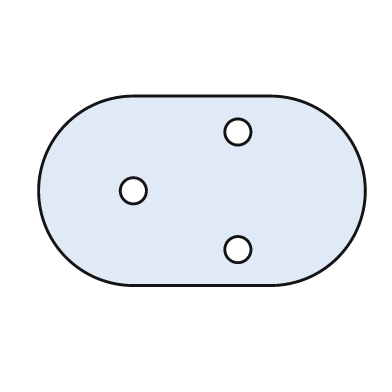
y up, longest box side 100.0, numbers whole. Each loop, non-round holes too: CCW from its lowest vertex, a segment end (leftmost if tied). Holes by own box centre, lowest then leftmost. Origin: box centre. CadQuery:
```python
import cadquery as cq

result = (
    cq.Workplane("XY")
    .moveTo(-21.0, -29.0)
    .lineTo(21.0, -29.0)
    .threePointArc((50.0, 0.0), (21.0, 29.0))
    .lineTo(-21.0, 29.0)
    .threePointArc((-50.0, 0.0), (-21.0, -29.0))
    .close()
    .moveTo(11.0, -18.0)
    .circle(4.0)
    .moveTo(-21.0, 0.0)
    .circle(4.0)
    .moveTo(11.0, 18.0)
    .circle(4.0)
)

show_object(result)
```